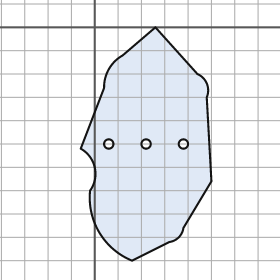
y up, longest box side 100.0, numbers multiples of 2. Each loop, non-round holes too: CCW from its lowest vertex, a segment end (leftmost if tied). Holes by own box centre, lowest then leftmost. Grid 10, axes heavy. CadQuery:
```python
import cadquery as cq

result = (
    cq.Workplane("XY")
    .moveTo(16.0, -100.0)
    .lineTo(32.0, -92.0)
    .threePointArc((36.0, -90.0), (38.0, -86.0))
    .lineTo(50.0, -66.0)
    .lineTo(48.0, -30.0)
    .threePointArc((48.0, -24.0), (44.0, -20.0))
    .lineTo(26.0, 0.0)
    .lineTo(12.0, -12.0)
    .threePointArc((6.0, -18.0), (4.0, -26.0))
    .lineTo(-6.0, -52.0)
    .threePointArc((0.0, -60.0), (-2.0, -70.0))
    .threePointArc((2.0, -88.0), (16.0, -100.0))
    .close()
    .moveTo(6.0, -50.0)
    .circle(2.0)
    .moveTo(22.0, -50.0)
    .circle(2.0)
    .moveTo(38.0, -50.0)
    .circle(2.0)
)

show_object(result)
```